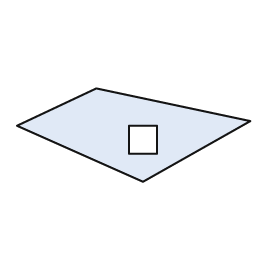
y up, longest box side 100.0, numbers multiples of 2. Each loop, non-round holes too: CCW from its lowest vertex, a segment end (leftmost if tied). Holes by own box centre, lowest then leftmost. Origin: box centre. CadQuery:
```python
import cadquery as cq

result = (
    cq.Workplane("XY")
    .moveTo(4.0, -20.0)
    .lineTo(50.0, 6.0)
    .lineTo(-16.0, 20.0)
    .lineTo(-50.0, 4.0)
    .close()
    .moveTo(-2.0, -8.0)
    .lineTo(10.0, -8.0)
    .lineTo(10.0, 4.0)
    .lineTo(-2.0, 4.0)
    .close()
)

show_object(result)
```